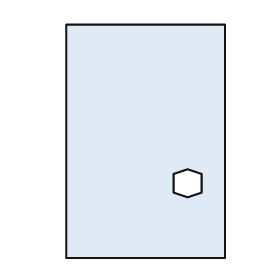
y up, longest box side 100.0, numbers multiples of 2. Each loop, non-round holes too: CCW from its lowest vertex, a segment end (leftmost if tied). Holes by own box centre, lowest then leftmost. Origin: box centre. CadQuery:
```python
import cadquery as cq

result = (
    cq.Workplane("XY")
    .moveTo(-34.0, -50.0)
    .lineTo(34.0, -50.0)
    .lineTo(34.0, 50.0)
    .lineTo(-34.0, 50.0)
    .close()
    .moveTo(18.0, -24.0)
    .lineTo(24.0, -22.0)
    .lineTo(24.0, -14.0)
    .lineTo(18.0, -12.0)
    .lineTo(12.0, -14.0)
    .lineTo(12.0, -22.0)
    .close()
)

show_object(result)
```